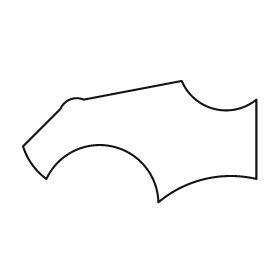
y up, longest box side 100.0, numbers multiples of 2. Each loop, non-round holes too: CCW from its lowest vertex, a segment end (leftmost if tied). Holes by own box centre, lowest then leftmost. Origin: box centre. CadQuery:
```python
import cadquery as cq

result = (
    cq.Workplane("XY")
    .moveTo(8.0, -26.0)
    .threePointArc((28.0, -16.0), (50.0, -16.0))
    .lineTo(50.0, 18.0)
    .threePointArc((32.0, 14.0), (18.0, 26.0))
    .lineTo(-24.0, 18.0)
    .threePointArc((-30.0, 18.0), (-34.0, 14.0))
    .lineTo(-50.0, -2.0)
    .threePointArc((-46.0, -10.0), (-40.0, -16.0))
    .threePointArc((-12.0, -2.0), (8.0, -26.0))
    .close()
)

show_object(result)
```